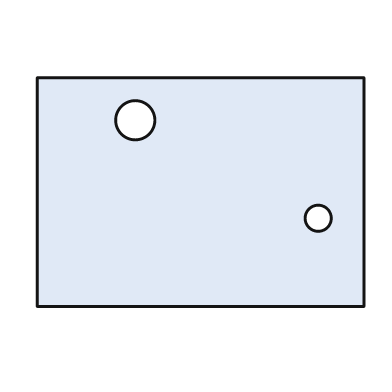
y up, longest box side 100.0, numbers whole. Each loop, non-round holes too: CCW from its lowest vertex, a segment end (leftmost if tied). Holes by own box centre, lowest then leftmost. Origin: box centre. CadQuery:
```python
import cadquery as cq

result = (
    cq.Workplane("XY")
    .moveTo(-50.0, -35.0)
    .lineTo(50.0, -35.0)
    .lineTo(50.0, 35.0)
    .lineTo(-50.0, 35.0)
    .close()
    .moveTo(36.0, -8.0)
    .circle(4.0)
    .moveTo(-20.0, 22.0)
    .circle(6.0)
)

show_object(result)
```